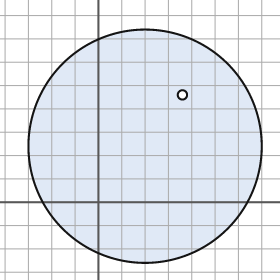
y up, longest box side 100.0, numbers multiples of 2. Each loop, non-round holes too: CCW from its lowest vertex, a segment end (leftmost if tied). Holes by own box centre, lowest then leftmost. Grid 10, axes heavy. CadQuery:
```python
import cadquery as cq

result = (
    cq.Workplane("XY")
    .moveTo(20.0, 24.0)
    .circle(50.0)
    .moveTo(36.0, 46.0)
    .circle(2.0)
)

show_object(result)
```